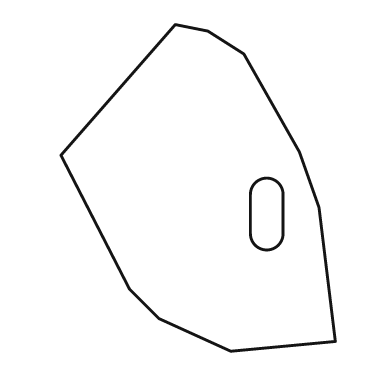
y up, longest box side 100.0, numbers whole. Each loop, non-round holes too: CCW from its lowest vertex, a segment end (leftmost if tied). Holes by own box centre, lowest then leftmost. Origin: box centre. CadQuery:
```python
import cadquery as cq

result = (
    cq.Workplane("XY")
    .moveTo(10.0, -50.0)
    .lineTo(42.0, -47.0)
    .lineTo(37.0, -6.0)
    .lineTo(31.0, 11.0)
    .lineTo(14.0, 41.0)
    .lineTo(3.0, 48.0)
    .lineTo(-7.0, 50.0)
    .lineTo(-42.0, 10.0)
    .lineTo(-21.0, -31.0)
    .lineTo(-12.0, -40.0)
    .close()
    .moveTo(16.0, -14.0)
    .threePointArc((21.0, -19.0), (26.0, -14.0))
    .lineTo(26.0, -2.0)
    .threePointArc((21.0, 3.0), (16.0, -2.0))
    .close()
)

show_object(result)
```